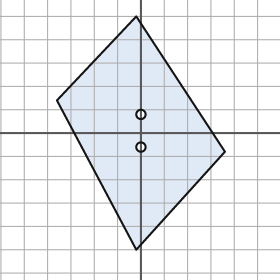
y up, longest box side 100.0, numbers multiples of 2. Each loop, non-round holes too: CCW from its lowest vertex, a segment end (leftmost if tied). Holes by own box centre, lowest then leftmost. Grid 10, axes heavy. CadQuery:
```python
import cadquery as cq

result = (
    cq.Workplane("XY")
    .moveTo(-2.0, -50.0)
    .lineTo(36.0, -8.0)
    .lineTo(-2.0, 50.0)
    .lineTo(-36.0, 14.0)
    .close()
    .moveTo(0.0, -6.0)
    .circle(2.0)
    .moveTo(0.0, 8.0)
    .circle(2.0)
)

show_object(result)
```